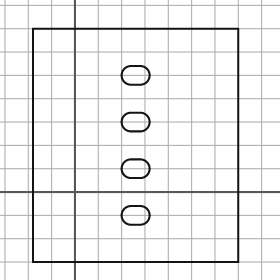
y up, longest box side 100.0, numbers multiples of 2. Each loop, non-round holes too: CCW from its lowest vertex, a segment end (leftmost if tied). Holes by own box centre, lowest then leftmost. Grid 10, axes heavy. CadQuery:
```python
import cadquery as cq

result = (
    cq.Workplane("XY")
    .moveTo(-18.0, -30.0)
    .lineTo(70.0, -30.0)
    .lineTo(70.0, 70.0)
    .lineTo(-18.0, 70.0)
    .close()
    .moveTo(24.0, -14.0)
    .lineTo(28.0, -14.0)
    .threePointArc((32.0, -10.0), (28.0, -6.0))
    .lineTo(24.0, -6.0)
    .threePointArc((20.0, -10.0), (24.0, -14.0))
    .close()
    .moveTo(24.0, 6.0)
    .lineTo(28.0, 6.0)
    .threePointArc((32.0, 10.0), (28.0, 14.0))
    .lineTo(24.0, 14.0)
    .threePointArc((20.0, 10.0), (24.0, 6.0))
    .close()
    .moveTo(24.0, 26.0)
    .lineTo(28.0, 26.0)
    .threePointArc((32.0, 30.0), (28.0, 34.0))
    .lineTo(24.0, 34.0)
    .threePointArc((20.0, 30.0), (24.0, 26.0))
    .close()
    .moveTo(24.0, 46.0)
    .lineTo(28.0, 46.0)
    .threePointArc((32.0, 50.0), (28.0, 54.0))
    .lineTo(24.0, 54.0)
    .threePointArc((20.0, 50.0), (24.0, 46.0))
    .close()
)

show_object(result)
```